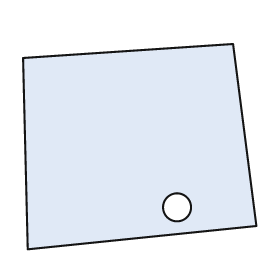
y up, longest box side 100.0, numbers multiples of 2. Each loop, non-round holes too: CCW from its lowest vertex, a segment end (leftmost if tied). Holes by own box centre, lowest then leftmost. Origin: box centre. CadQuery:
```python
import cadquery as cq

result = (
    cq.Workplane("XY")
    .moveTo(-48.0, -44.0)
    .lineTo(50.0, -34.0)
    .lineTo(40.0, 44.0)
    .lineTo(-50.0, 38.0)
    .close()
    .moveTo(16.0, -26.0)
    .circle(6.0)
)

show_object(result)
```